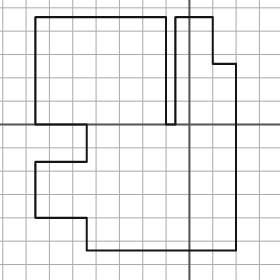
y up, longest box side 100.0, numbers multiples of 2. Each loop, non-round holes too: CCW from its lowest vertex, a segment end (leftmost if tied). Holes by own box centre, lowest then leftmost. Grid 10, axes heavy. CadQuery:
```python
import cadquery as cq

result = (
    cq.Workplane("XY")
    .moveTo(-44.0, -54.0)
    .lineTo(20.0, -54.0)
    .lineTo(20.0, 26.0)
    .lineTo(10.0, 26.0)
    .lineTo(10.0, 46.0)
    .lineTo(-6.0, 46.0)
    .lineTo(-6.0, 0.0)
    .lineTo(-10.0, 0.0)
    .lineTo(-10.0, 46.0)
    .lineTo(-66.0, 46.0)
    .lineTo(-66.0, 0.0)
    .lineTo(-44.0, 0.0)
    .lineTo(-44.0, -16.0)
    .lineTo(-66.0, -16.0)
    .lineTo(-66.0, -40.0)
    .lineTo(-44.0, -40.0)
    .close()
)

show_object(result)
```